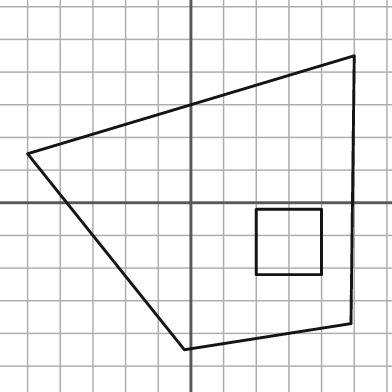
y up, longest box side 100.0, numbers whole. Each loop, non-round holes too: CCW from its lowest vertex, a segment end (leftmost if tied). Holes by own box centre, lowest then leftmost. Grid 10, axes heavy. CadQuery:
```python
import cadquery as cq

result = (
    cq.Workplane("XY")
    .moveTo(-2.0, -45.0)
    .lineTo(49.0, -37.0)
    .lineTo(50.0, 45.0)
    .lineTo(-50.0, 15.0)
    .close()
    .moveTo(20.0, -22.0)
    .lineTo(40.0, -22.0)
    .lineTo(40.0, -2.0)
    .lineTo(20.0, -2.0)
    .close()
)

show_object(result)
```